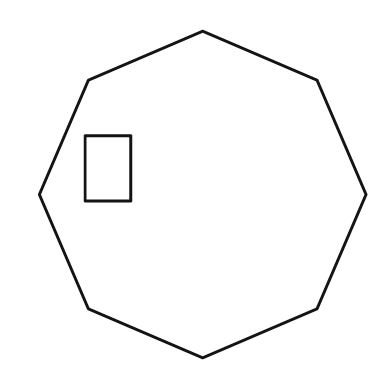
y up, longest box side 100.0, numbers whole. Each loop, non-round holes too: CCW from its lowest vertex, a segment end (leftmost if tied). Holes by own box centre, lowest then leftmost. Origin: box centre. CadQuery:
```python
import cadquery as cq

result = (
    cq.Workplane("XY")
    .moveTo(0.0, -50.0)
    .lineTo(35.0, -35.0)
    .lineTo(50.0, 0.0)
    .lineTo(35.0, 35.0)
    .lineTo(0.0, 50.0)
    .lineTo(-35.0, 35.0)
    .lineTo(-50.0, 0.0)
    .lineTo(-35.0, -35.0)
    .close()
    .moveTo(-36.0, -2.0)
    .lineTo(-22.0, -2.0)
    .lineTo(-22.0, 18.0)
    .lineTo(-36.0, 18.0)
    .close()
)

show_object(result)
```